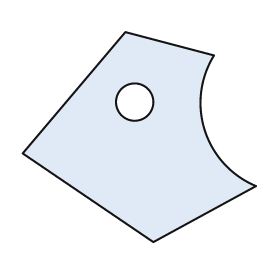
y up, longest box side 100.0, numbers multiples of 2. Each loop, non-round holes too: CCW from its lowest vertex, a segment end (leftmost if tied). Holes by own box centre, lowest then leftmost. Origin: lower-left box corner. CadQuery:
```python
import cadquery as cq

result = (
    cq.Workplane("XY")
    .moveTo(56.0, 0.0)
    .lineTo(100.0, 24.0)
    .threePointArc((78.0, 48.0), (82.0, 80.0))
    .lineTo(44.0, 90.0)
    .lineTo(0.0, 38.0)
    .close()
    .moveTo(48.0, 60.0)
    .circle(8.0)
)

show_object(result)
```